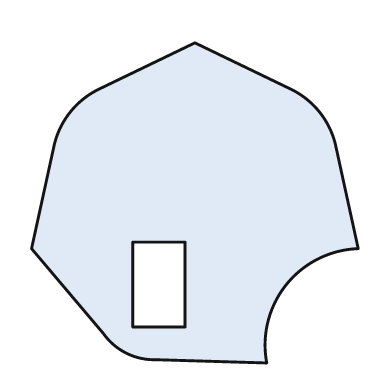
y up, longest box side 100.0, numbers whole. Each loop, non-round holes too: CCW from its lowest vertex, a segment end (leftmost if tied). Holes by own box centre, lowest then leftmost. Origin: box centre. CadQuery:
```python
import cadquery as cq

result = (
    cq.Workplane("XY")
    .moveTo(22.0, -49.0)
    .threePointArc((28.0, -25.0), (50.0, -14.0))
    .lineTo(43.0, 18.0)
    .threePointArc((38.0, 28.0), (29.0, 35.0))
    .lineTo(0.0, 49.0)
    .lineTo(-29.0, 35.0)
    .threePointArc((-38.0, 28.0), (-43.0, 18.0))
    .lineTo(-50.0, -14.0)
    .lineTo(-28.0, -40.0)
    .threePointArc((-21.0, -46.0), (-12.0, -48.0))
    .close()
    .moveTo(-19.0, -38.0)
    .lineTo(-3.0, -38.0)
    .lineTo(-3.0, -12.0)
    .lineTo(-19.0, -12.0)
    .close()
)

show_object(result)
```